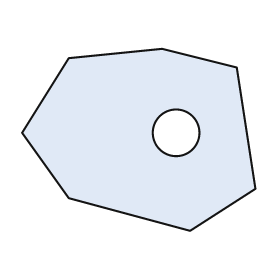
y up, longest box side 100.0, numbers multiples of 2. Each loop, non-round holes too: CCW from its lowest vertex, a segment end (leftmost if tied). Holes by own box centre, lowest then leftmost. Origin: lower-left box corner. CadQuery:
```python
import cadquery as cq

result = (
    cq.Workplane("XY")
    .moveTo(72.0, 0.0)
    .lineTo(100.0, 18.0)
    .lineTo(92.0, 70.0)
    .lineTo(60.0, 78.0)
    .lineTo(20.0, 74.0)
    .lineTo(0.0, 42.0)
    .lineTo(20.0, 14.0)
    .close()
    .moveTo(66.0, 42.0)
    .circle(10.0)
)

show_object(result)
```